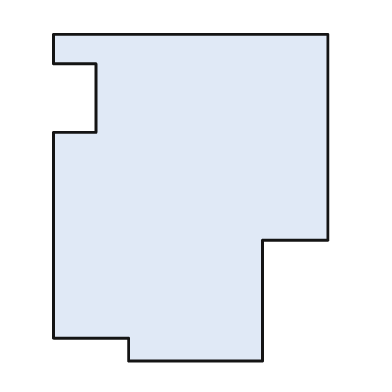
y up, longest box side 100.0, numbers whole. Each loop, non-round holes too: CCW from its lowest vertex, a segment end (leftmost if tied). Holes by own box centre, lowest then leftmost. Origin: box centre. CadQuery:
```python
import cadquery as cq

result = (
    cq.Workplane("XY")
    .moveTo(-19.0, -50.0)
    .lineTo(22.0, -50.0)
    .lineTo(22.0, -13.0)
    .lineTo(42.0, -13.0)
    .lineTo(42.0, 50.0)
    .lineTo(-42.0, 50.0)
    .lineTo(-42.0, 41.0)
    .lineTo(-29.0, 41.0)
    .lineTo(-29.0, 20.0)
    .lineTo(-42.0, 20.0)
    .lineTo(-42.0, -43.0)
    .lineTo(-19.0, -43.0)
    .close()
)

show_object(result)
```